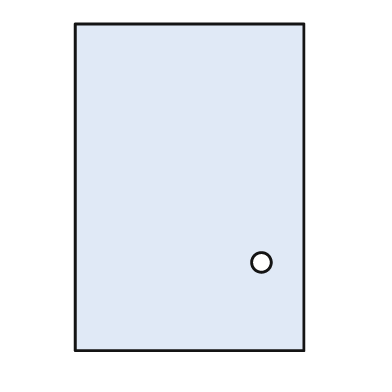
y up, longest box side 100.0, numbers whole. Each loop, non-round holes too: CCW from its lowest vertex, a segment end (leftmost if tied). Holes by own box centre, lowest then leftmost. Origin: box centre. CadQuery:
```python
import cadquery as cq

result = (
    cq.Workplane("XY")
    .moveTo(-35.0, -50.0)
    .lineTo(35.0, -50.0)
    .lineTo(35.0, 50.0)
    .lineTo(-35.0, 50.0)
    .close()
    .moveTo(22.0, -23.0)
    .circle(3.0)
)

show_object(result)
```